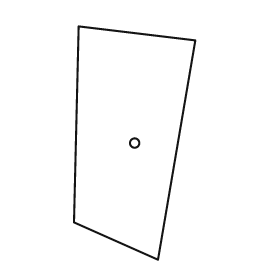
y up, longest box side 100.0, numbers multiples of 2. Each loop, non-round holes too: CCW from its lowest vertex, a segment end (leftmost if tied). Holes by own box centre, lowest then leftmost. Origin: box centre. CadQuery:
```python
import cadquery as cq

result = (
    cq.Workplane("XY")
    .moveTo(10.0, -50.0)
    .lineTo(26.0, 44.0)
    .lineTo(-24.0, 50.0)
    .lineTo(-26.0, -34.0)
    .close()
    .moveTo(0.0, 0.0)
    .circle(2.0)
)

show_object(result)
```